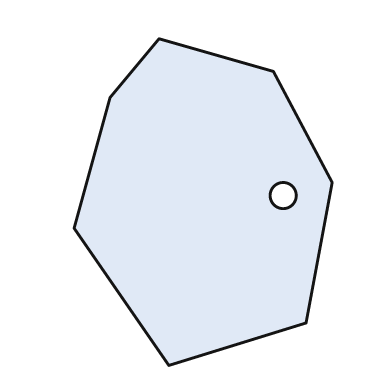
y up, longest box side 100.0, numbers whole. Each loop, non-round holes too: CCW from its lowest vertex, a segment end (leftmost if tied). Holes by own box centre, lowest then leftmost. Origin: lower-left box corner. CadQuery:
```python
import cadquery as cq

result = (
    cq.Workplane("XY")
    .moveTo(29.0, 0.0)
    .lineTo(71.0, 13.0)
    .lineTo(79.0, 56.0)
    .lineTo(61.0, 90.0)
    .lineTo(26.0, 100.0)
    .lineTo(11.0, 82.0)
    .lineTo(0.0, 42.0)
    .close()
    .moveTo(64.0, 52.0)
    .circle(4.0)
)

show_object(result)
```